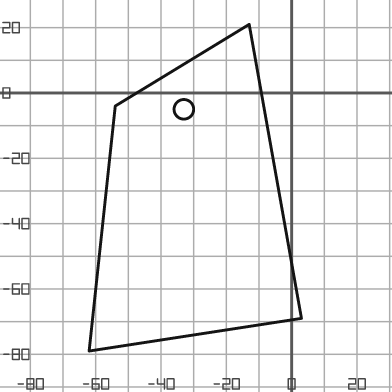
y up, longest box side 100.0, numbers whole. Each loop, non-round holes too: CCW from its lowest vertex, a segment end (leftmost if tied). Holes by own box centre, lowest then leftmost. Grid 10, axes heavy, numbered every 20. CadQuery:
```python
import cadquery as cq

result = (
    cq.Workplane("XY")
    .moveTo(-62.0, -79.0)
    .lineTo(3.0, -69.0)
    .lineTo(-13.0, 21.0)
    .lineTo(-54.0, -4.0)
    .close()
    .moveTo(-33.0, -5.0)
    .circle(3.0)
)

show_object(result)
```